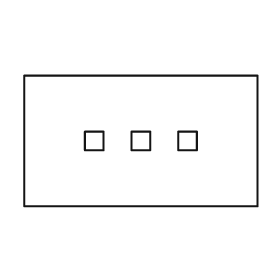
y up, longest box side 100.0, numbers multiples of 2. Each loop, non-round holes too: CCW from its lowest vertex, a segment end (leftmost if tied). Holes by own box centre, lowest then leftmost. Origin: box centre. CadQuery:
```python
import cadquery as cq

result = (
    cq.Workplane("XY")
    .moveTo(-50.0, -28.0)
    .lineTo(50.0, -28.0)
    .lineTo(50.0, 28.0)
    .lineTo(-50.0, 28.0)
    .close()
    .moveTo(-24.0, -4.0)
    .lineTo(-16.0, -4.0)
    .lineTo(-16.0, 4.0)
    .lineTo(-24.0, 4.0)
    .close()
    .moveTo(-4.0, -4.0)
    .lineTo(4.0, -4.0)
    .lineTo(4.0, 4.0)
    .lineTo(-4.0, 4.0)
    .close()
    .moveTo(16.0, -4.0)
    .lineTo(24.0, -4.0)
    .lineTo(24.0, 4.0)
    .lineTo(16.0, 4.0)
    .close()
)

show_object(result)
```